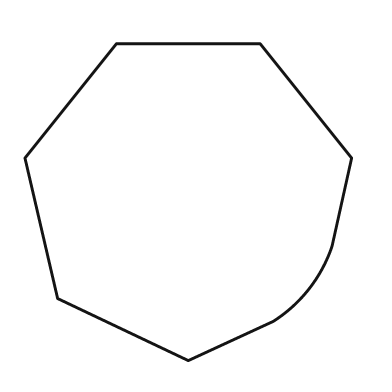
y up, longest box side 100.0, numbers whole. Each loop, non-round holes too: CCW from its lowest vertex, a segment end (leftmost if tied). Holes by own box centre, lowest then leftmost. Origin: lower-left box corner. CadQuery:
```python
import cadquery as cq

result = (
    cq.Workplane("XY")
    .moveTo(50.0, 0.0)
    .lineTo(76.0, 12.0)
    .threePointArc((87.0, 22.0), (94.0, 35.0))
    .lineTo(100.0, 62.0)
    .lineTo(72.0, 97.0)
    .lineTo(28.0, 97.0)
    .lineTo(0.0, 62.0)
    .lineTo(10.0, 19.0)
    .close()
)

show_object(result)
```